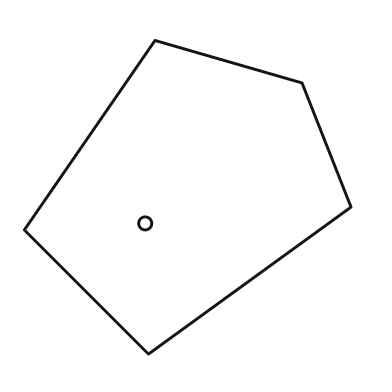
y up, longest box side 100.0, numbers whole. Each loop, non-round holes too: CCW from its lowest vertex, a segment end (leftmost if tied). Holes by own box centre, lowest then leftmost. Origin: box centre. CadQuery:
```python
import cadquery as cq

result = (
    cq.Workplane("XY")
    .moveTo(-12.0, -48.0)
    .lineTo(50.0, -3.0)
    .lineTo(35.0, 35.0)
    .lineTo(-10.0, 48.0)
    .lineTo(-50.0, -10.0)
    .close()
    .moveTo(-13.0, -8.0)
    .circle(2.0)
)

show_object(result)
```